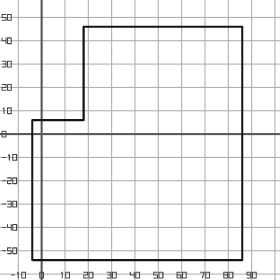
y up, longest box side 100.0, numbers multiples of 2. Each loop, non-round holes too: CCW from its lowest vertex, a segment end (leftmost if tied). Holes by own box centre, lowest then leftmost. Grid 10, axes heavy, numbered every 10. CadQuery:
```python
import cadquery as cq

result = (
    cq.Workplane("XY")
    .moveTo(-4.0, -54.0)
    .lineTo(86.0, -54.0)
    .lineTo(86.0, 46.0)
    .lineTo(18.0, 46.0)
    .lineTo(18.0, 6.0)
    .lineTo(-4.0, 6.0)
    .close()
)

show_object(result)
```